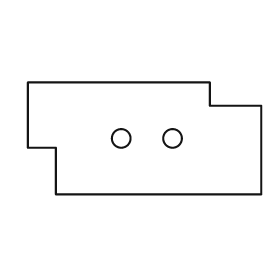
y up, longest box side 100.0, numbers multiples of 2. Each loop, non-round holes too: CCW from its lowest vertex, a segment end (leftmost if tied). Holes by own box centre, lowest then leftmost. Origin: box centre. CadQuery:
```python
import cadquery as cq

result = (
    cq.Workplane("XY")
    .moveTo(-38.0, -24.0)
    .lineTo(50.0, -24.0)
    .lineTo(50.0, 14.0)
    .lineTo(28.0, 14.0)
    .lineTo(28.0, 24.0)
    .lineTo(-50.0, 24.0)
    .lineTo(-50.0, -4.0)
    .lineTo(-38.0, -4.0)
    .close()
    .moveTo(-10.0, 0.0)
    .circle(4.0)
    .moveTo(12.0, 0.0)
    .circle(4.0)
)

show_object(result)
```